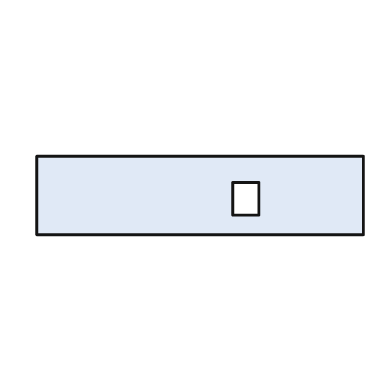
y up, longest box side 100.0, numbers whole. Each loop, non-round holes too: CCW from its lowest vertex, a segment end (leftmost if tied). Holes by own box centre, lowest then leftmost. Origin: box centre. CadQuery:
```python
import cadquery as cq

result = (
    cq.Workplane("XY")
    .moveTo(-50.0, -12.0)
    .lineTo(50.0, -12.0)
    .lineTo(50.0, 12.0)
    .lineTo(-50.0, 12.0)
    .close()
    .moveTo(10.0, -6.0)
    .lineTo(18.0, -6.0)
    .lineTo(18.0, 4.0)
    .lineTo(10.0, 4.0)
    .close()
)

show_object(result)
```